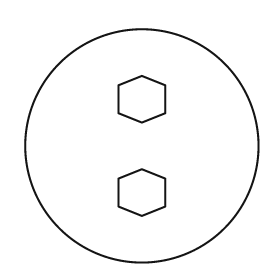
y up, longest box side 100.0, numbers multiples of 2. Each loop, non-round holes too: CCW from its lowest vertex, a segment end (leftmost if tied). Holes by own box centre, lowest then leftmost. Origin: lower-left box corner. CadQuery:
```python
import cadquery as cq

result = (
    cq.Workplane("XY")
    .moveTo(50.0, 50.0)
    .circle(50.0)
    .moveTo(50.0, 20.0)
    .lineTo(60.0, 24.0)
    .lineTo(60.0, 36.0)
    .lineTo(50.0, 40.0)
    .lineTo(40.0, 36.0)
    .lineTo(40.0, 24.0)
    .close()
    .moveTo(50.0, 60.0)
    .lineTo(60.0, 64.0)
    .lineTo(60.0, 76.0)
    .lineTo(50.0, 80.0)
    .lineTo(40.0, 76.0)
    .lineTo(40.0, 64.0)
    .close()
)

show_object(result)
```